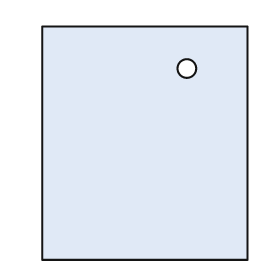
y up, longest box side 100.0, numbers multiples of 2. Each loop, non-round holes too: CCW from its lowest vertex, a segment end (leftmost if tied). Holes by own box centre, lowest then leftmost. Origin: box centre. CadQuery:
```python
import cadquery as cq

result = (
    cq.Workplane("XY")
    .moveTo(-44.0, -50.0)
    .lineTo(44.0, -50.0)
    .lineTo(44.0, 50.0)
    .lineTo(-44.0, 50.0)
    .close()
    .moveTo(18.0, 32.0)
    .circle(4.0)
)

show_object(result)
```